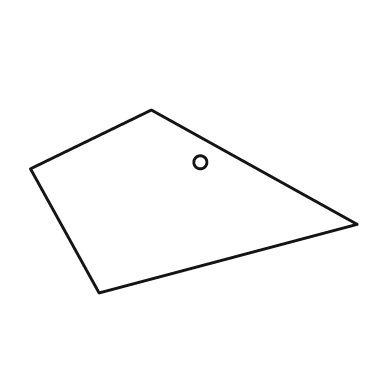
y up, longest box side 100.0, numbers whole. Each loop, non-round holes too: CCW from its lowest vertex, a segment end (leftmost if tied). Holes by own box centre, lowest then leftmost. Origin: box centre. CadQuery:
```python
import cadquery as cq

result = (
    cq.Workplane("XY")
    .moveTo(-29.0, -28.0)
    .lineTo(50.0, -7.0)
    .lineTo(-13.0, 28.0)
    .lineTo(-50.0, 10.0)
    .close()
    .moveTo(2.0, 12.0)
    .circle(2.0)
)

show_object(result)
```